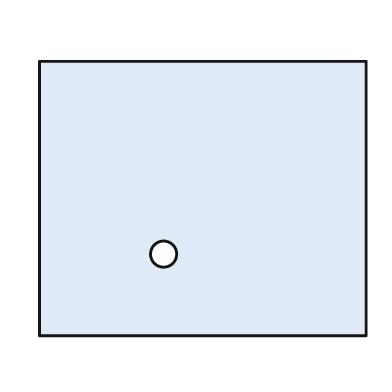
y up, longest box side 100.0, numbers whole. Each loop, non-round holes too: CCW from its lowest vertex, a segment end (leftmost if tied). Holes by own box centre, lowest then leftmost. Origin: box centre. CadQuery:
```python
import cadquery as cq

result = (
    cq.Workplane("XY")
    .moveTo(-50.0, -42.0)
    .lineTo(50.0, -42.0)
    .lineTo(50.0, 42.0)
    .lineTo(-50.0, 42.0)
    .close()
    .moveTo(-12.0, -17.0)
    .circle(4.0)
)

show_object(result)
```